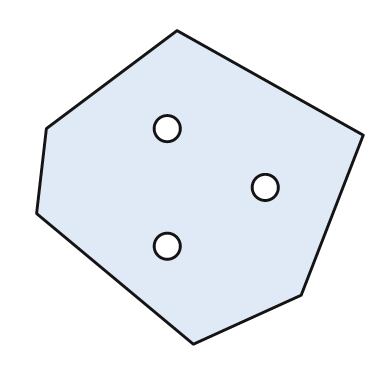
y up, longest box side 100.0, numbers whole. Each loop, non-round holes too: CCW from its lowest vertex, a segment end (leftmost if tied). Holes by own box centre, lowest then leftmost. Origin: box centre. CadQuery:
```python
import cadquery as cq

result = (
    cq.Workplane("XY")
    .moveTo(-2.0, -48.0)
    .lineTo(31.0, -33.0)
    .lineTo(50.0, 16.0)
    .lineTo(-7.0, 48.0)
    .lineTo(-47.0, 18.0)
    .lineTo(-50.0, -8.0)
    .close()
    .moveTo(-10.0, -18.0)
    .circle(4.0)
    .moveTo(20.0, 0.0)
    .circle(4.0)
    .moveTo(-10.0, 18.0)
    .circle(4.0)
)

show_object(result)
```